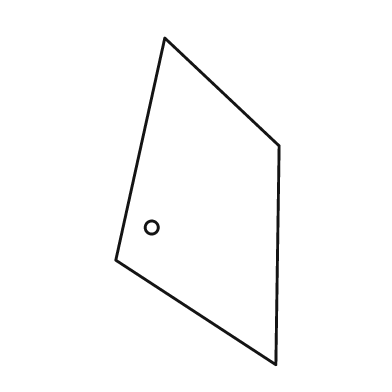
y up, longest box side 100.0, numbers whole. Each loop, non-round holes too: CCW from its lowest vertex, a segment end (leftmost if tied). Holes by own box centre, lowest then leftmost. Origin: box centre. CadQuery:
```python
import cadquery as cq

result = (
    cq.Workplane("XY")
    .moveTo(24.0, -50.0)
    .lineTo(25.0, 17.0)
    .lineTo(-10.0, 50.0)
    .lineTo(-25.0, -18.0)
    .close()
    .moveTo(-14.0, -8.0)
    .circle(2.0)
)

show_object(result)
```